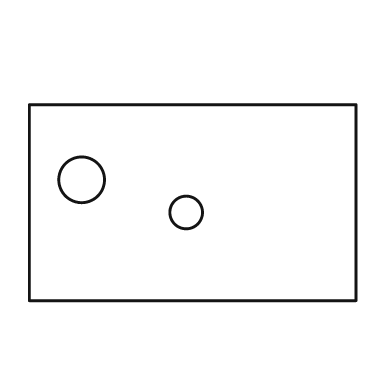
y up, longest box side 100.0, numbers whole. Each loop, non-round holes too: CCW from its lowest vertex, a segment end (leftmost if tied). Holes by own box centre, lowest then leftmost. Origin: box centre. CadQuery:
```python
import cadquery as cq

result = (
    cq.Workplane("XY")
    .moveTo(-50.0, -30.0)
    .lineTo(50.0, -30.0)
    .lineTo(50.0, 30.0)
    .lineTo(-50.0, 30.0)
    .close()
    .moveTo(-2.0, -3.0)
    .circle(5.0)
    .moveTo(-34.0, 7.0)
    .circle(7.0)
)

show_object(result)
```